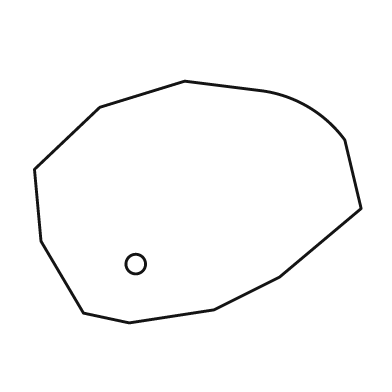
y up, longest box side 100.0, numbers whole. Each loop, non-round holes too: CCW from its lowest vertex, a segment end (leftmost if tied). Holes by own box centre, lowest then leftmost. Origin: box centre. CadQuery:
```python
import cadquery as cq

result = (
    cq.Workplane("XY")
    .moveTo(-21.0, -37.0)
    .lineTo(5.0, -33.0)
    .lineTo(25.0, -23.0)
    .lineTo(50.0, -2.0)
    .lineTo(45.0, 19.0)
    .threePointArc((34.0, 29.0), (20.0, 34.0))
    .lineTo(-4.0, 37.0)
    .lineTo(-30.0, 29.0)
    .lineTo(-50.0, 10.0)
    .lineTo(-48.0, -12.0)
    .lineTo(-35.0, -34.0)
    .close()
    .moveTo(-19.0, -19.0)
    .circle(3.0)
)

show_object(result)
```